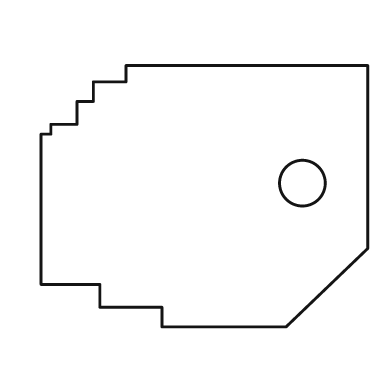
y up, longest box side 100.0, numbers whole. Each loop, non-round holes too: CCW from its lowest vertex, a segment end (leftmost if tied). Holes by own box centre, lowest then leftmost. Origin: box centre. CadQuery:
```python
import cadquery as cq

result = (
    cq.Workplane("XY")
    .moveTo(-13.0, -40.0)
    .lineTo(25.0, -40.0)
    .lineTo(50.0, -16.0)
    .lineTo(50.0, 40.0)
    .lineTo(-24.0, 40.0)
    .lineTo(-24.0, 35.0)
    .lineTo(-34.0, 35.0)
    .lineTo(-34.0, 29.0)
    .lineTo(-39.0, 29.0)
    .lineTo(-39.0, 22.0)
    .lineTo(-47.0, 22.0)
    .lineTo(-47.0, 19.0)
    .lineTo(-50.0, 19.0)
    .lineTo(-50.0, -27.0)
    .lineTo(-32.0, -27.0)
    .lineTo(-32.0, -34.0)
    .lineTo(-13.0, -34.0)
    .close()
    .moveTo(30.0, 4.0)
    .circle(7.0)
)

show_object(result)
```